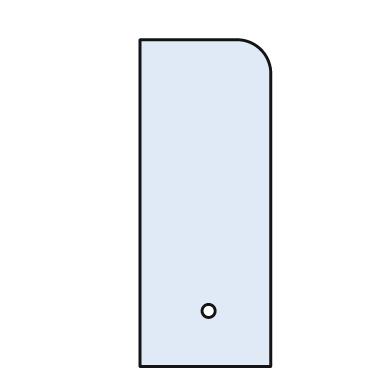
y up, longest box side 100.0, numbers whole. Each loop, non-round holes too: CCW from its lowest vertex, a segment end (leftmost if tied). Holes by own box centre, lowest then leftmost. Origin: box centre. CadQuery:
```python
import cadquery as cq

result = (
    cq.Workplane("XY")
    .moveTo(-20.0, -50.0)
    .lineTo(20.0, -50.0)
    .lineTo(20.0, 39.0)
    .threePointArc((17.0, 47.0), (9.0, 50.0))
    .lineTo(-20.0, 50.0)
    .close()
    .moveTo(1.0, -33.0)
    .circle(2.0)
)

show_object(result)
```